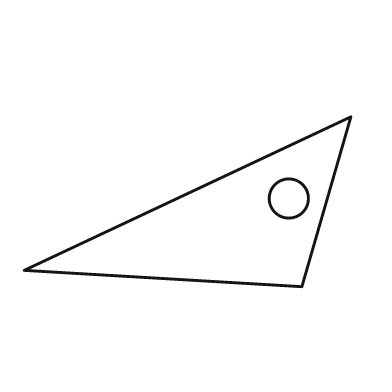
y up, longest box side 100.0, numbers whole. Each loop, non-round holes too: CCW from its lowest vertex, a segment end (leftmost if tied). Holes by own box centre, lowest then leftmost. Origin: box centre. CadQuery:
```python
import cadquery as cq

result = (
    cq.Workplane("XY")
    .moveTo(35.0, -26.0)
    .lineTo(50.0, 26.0)
    .lineTo(-50.0, -21.0)
    .close()
    .moveTo(31.0, 1.0)
    .circle(6.0)
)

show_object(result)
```